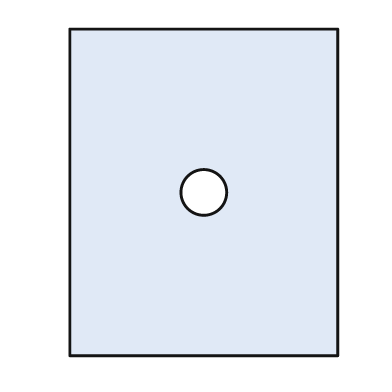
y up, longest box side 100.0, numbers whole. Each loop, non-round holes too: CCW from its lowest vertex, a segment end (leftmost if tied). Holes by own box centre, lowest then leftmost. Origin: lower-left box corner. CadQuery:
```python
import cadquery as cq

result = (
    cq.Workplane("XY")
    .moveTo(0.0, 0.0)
    .lineTo(82.0, 0.0)
    .lineTo(82.0, 100.0)
    .lineTo(0.0, 100.0)
    .close()
    .moveTo(41.0, 50.0)
    .circle(7.0)
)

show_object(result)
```